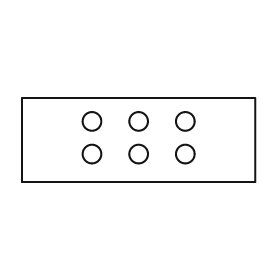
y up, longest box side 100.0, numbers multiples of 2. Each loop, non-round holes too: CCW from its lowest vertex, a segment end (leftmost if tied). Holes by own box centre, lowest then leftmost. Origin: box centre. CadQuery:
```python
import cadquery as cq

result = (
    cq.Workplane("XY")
    .moveTo(-50.0, -18.0)
    .lineTo(50.0, -18.0)
    .lineTo(50.0, 18.0)
    .lineTo(-50.0, 18.0)
    .close()
    .moveTo(-20.0, -6.0)
    .circle(4.0)
    .moveTo(0.0, -6.0)
    .circle(4.0)
    .moveTo(20.0, -6.0)
    .circle(4.0)
    .moveTo(-20.0, 8.0)
    .circle(4.0)
    .moveTo(0.0, 8.0)
    .circle(4.0)
    .moveTo(20.0, 8.0)
    .circle(4.0)
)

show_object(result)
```